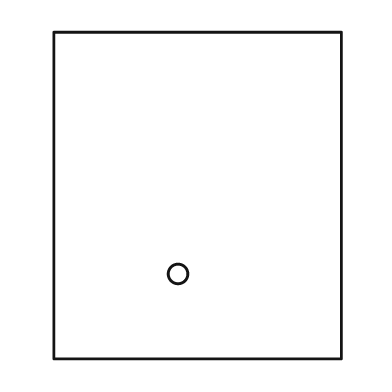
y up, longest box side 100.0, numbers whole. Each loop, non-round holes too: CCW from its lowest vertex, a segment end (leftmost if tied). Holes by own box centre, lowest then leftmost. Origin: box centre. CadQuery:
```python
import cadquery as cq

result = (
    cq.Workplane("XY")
    .moveTo(-44.0, -50.0)
    .lineTo(44.0, -50.0)
    .lineTo(44.0, 50.0)
    .lineTo(-44.0, 50.0)
    .close()
    .moveTo(-6.0, -24.0)
    .circle(3.0)
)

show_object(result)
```